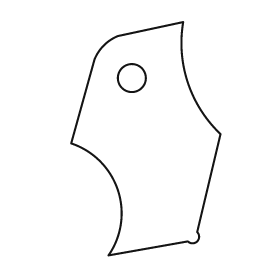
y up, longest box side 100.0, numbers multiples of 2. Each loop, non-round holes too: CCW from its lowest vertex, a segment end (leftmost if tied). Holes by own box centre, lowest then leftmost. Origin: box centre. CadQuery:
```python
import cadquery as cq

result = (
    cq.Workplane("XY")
    .moveTo(-16.0, -50.0)
    .lineTo(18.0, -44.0)
    .threePointArc((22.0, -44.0), (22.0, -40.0))
    .lineTo(32.0, 2.0)
    .threePointArc((18.0, 24.0), (16.0, 50.0))
    .lineTo(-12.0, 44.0)
    .threePointArc((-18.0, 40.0), (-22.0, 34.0))
    .lineTo(-32.0, -2.0)
    .threePointArc((-12.0, -22.0), (-16.0, -50.0))
    .close()
    .moveTo(-6.0, 26.0)
    .circle(6.0)
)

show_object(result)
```